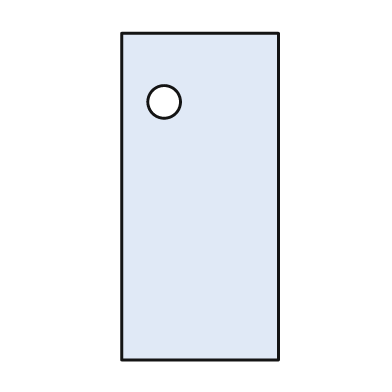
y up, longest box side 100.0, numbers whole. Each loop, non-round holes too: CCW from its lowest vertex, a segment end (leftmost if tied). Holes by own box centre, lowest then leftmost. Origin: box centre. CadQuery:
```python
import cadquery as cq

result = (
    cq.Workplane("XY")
    .moveTo(-24.0, -50.0)
    .lineTo(24.0, -50.0)
    .lineTo(24.0, 50.0)
    .lineTo(-24.0, 50.0)
    .close()
    .moveTo(-11.0, 29.0)
    .circle(5.0)
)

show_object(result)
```